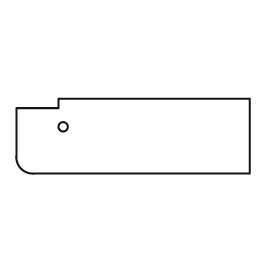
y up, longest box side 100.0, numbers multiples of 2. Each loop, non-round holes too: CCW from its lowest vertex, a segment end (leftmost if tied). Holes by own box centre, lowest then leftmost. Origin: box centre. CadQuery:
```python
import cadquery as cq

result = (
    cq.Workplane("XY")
    .moveTo(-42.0, -16.0)
    .lineTo(50.0, -16.0)
    .lineTo(50.0, 16.0)
    .lineTo(-32.0, 16.0)
    .lineTo(-32.0, 12.0)
    .lineTo(-50.0, 12.0)
    .lineTo(-50.0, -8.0)
    .threePointArc((-48.0, -14.0), (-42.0, -16.0))
    .close()
    .moveTo(-30.0, 4.0)
    .circle(2.0)
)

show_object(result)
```